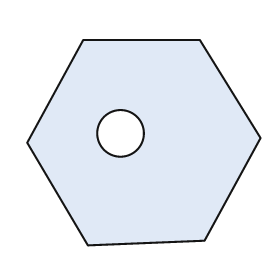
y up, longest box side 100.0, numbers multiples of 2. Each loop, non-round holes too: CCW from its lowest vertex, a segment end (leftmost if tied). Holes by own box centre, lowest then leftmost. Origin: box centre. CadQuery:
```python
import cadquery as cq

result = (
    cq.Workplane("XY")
    .moveTo(-24.0, -44.0)
    .lineTo(26.0, -42.0)
    .lineTo(50.0, 2.0)
    .lineTo(24.0, 44.0)
    .lineTo(-26.0, 44.0)
    .lineTo(-50.0, 0.0)
    .close()
    .moveTo(-10.0, 4.0)
    .circle(10.0)
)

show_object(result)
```